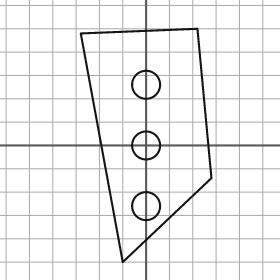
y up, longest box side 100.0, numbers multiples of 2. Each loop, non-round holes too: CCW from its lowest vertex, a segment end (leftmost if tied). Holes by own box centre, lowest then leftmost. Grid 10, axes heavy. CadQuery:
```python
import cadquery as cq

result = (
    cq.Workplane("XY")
    .moveTo(-10.0, -50.0)
    .lineTo(28.0, -14.0)
    .lineTo(22.0, 50.0)
    .lineTo(-28.0, 48.0)
    .close()
    .moveTo(0.0, -26.0)
    .circle(6.0)
    .moveTo(0.0, 0.0)
    .circle(6.0)
    .moveTo(0.0, 26.0)
    .circle(6.0)
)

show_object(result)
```